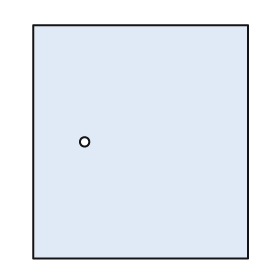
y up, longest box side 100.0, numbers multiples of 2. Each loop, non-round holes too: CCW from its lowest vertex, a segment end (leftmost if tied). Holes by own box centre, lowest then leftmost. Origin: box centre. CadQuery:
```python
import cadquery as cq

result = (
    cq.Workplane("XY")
    .moveTo(-46.0, -50.0)
    .lineTo(46.0, -50.0)
    .lineTo(46.0, 50.0)
    .lineTo(-46.0, 50.0)
    .close()
    .moveTo(-24.0, 0.0)
    .circle(2.0)
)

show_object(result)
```